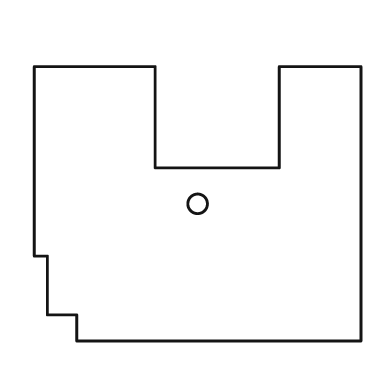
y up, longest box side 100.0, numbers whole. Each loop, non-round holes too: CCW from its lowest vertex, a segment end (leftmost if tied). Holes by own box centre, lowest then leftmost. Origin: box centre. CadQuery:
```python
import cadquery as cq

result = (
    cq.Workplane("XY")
    .moveTo(-37.0, -42.0)
    .lineTo(50.0, -42.0)
    .lineTo(50.0, 42.0)
    .lineTo(25.0, 42.0)
    .lineTo(25.0, 11.0)
    .lineTo(-13.0, 11.0)
    .lineTo(-13.0, 42.0)
    .lineTo(-50.0, 42.0)
    .lineTo(-50.0, -16.0)
    .lineTo(-46.0, -16.0)
    .lineTo(-46.0, -34.0)
    .lineTo(-37.0, -34.0)
    .close()
    .moveTo(0.0, 0.0)
    .circle(3.0)
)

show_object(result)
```